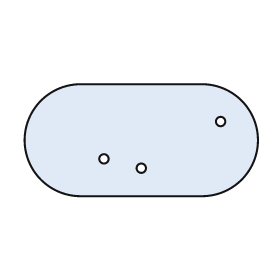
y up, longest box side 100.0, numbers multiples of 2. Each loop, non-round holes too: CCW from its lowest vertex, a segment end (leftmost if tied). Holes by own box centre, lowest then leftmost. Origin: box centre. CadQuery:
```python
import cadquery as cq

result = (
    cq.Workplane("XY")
    .moveTo(-26.0, -24.0)
    .lineTo(26.0, -24.0)
    .threePointArc((50.0, 0.0), (26.0, 24.0))
    .lineTo(-26.0, 24.0)
    .threePointArc((-50.0, 0.0), (-26.0, -24.0))
    .close()
    .moveTo(0.0, -12.0)
    .circle(2.0)
    .moveTo(-16.0, -8.0)
    .circle(2.0)
    .moveTo(34.0, 8.0)
    .circle(2.0)
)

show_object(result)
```